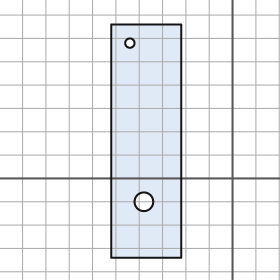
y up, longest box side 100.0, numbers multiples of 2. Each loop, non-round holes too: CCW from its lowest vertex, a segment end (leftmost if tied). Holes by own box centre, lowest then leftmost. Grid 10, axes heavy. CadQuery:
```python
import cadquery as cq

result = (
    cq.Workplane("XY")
    .moveTo(-52.0, -34.0)
    .lineTo(-22.0, -34.0)
    .lineTo(-22.0, 66.0)
    .lineTo(-52.0, 66.0)
    .close()
    .moveTo(-38.0, -10.0)
    .circle(4.0)
    .moveTo(-44.0, 58.0)
    .circle(2.0)
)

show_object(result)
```